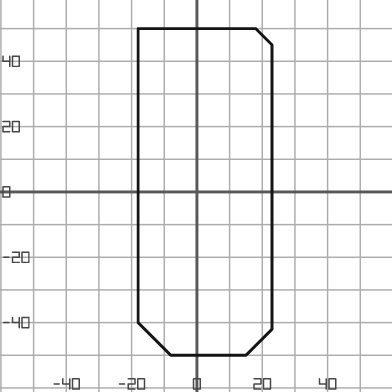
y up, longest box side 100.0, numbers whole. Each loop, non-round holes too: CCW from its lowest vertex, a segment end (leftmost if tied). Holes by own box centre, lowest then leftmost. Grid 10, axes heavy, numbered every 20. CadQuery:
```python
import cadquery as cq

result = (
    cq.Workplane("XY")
    .moveTo(-8.0, -50.0)
    .lineTo(15.0, -50.0)
    .lineTo(23.0, -42.0)
    .lineTo(23.0, 45.0)
    .lineTo(18.0, 50.0)
    .lineTo(-18.0, 50.0)
    .lineTo(-18.0, -40.0)
    .close()
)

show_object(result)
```